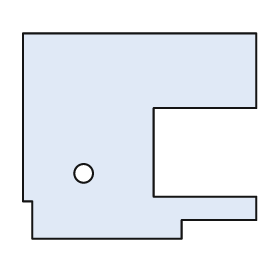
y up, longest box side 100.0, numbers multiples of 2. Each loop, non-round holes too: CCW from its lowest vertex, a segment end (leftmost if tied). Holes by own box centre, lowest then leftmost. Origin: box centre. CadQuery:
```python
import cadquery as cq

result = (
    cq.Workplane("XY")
    .moveTo(-46.0, -44.0)
    .lineTo(18.0, -44.0)
    .lineTo(18.0, -36.0)
    .lineTo(50.0, -36.0)
    .lineTo(50.0, -26.0)
    .lineTo(6.0, -26.0)
    .lineTo(6.0, 12.0)
    .lineTo(50.0, 12.0)
    .lineTo(50.0, 44.0)
    .lineTo(-50.0, 44.0)
    .lineTo(-50.0, -28.0)
    .lineTo(-46.0, -28.0)
    .close()
    .moveTo(-24.0, -16.0)
    .circle(4.0)
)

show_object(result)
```